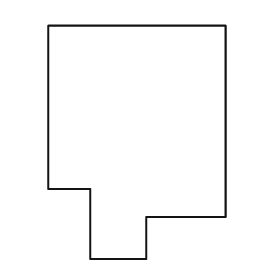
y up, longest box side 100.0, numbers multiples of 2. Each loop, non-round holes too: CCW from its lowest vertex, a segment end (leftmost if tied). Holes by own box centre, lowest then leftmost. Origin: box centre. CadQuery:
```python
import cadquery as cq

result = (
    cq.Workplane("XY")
    .moveTo(-20.0, -50.0)
    .lineTo(4.0, -50.0)
    .lineTo(4.0, -32.0)
    .lineTo(38.0, -32.0)
    .lineTo(38.0, 50.0)
    .lineTo(-38.0, 50.0)
    .lineTo(-38.0, -20.0)
    .lineTo(-20.0, -20.0)
    .close()
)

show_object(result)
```